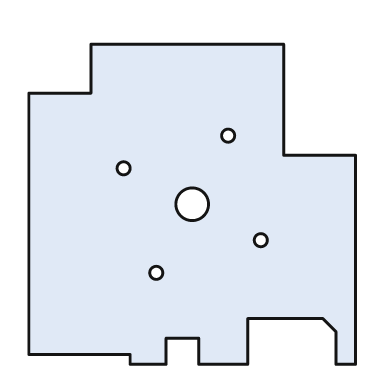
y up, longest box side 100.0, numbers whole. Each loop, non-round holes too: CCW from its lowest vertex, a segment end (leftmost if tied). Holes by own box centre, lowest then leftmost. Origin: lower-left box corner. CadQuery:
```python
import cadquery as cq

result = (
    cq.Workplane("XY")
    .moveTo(31.0, 0.0)
    .lineTo(42.0, 0.0)
    .lineTo(42.0, 8.0)
    .lineTo(52.0, 8.0)
    .lineTo(52.0, 0.0)
    .lineTo(67.0, 0.0)
    .lineTo(67.0, 14.0)
    .lineTo(90.0, 14.0)
    .lineTo(94.0, 10.0)
    .lineTo(94.0, 0.0)
    .lineTo(100.0, 0.0)
    .lineTo(100.0, 64.0)
    .lineTo(78.0, 64.0)
    .lineTo(78.0, 98.0)
    .lineTo(19.0, 98.0)
    .lineTo(19.0, 83.0)
    .lineTo(0.0, 83.0)
    .lineTo(0.0, 3.0)
    .lineTo(31.0, 3.0)
    .close()
    .moveTo(39.0, 28.0)
    .circle(2.0)
    .moveTo(71.0, 38.0)
    .circle(2.0)
    .moveTo(50.0, 49.0)
    .circle(5.0)
    .moveTo(29.0, 60.0)
    .circle(2.0)
    .moveTo(61.0, 70.0)
    .circle(2.0)
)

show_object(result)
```